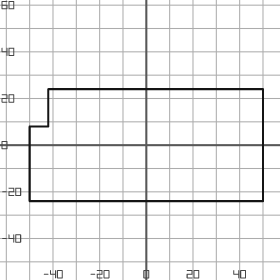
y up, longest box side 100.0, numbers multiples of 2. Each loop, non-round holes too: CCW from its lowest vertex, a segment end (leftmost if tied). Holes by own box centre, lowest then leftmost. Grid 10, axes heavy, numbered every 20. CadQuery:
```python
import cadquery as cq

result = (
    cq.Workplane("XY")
    .moveTo(-50.0, -24.0)
    .lineTo(50.0, -24.0)
    .lineTo(50.0, 24.0)
    .lineTo(-42.0, 24.0)
    .lineTo(-42.0, 8.0)
    .lineTo(-50.0, 8.0)
    .close()
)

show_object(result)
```